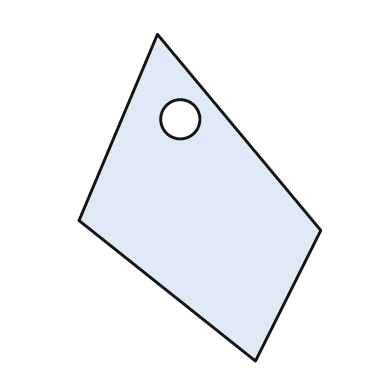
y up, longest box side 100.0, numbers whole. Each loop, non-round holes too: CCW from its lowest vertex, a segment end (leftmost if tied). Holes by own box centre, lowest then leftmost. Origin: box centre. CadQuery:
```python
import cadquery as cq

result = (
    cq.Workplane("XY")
    .moveTo(17.0, -50.0)
    .lineTo(37.0, -10.0)
    .lineTo(-13.0, 50.0)
    .lineTo(-37.0, -7.0)
    .close()
    .moveTo(-6.0, 24.0)
    .circle(6.0)
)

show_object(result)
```